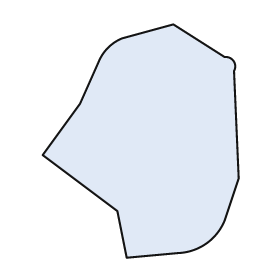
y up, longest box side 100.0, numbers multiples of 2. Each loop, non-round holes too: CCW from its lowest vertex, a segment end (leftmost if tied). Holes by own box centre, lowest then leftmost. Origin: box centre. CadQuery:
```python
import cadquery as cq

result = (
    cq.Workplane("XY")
    .moveTo(-6.0, -50.0)
    .lineTo(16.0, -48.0)
    .threePointArc((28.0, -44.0), (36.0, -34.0))
    .lineTo(42.0, -16.0)
    .lineTo(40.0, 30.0)
    .threePointArc((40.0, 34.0), (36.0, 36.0))
    .lineTo(14.0, 50.0)
    .lineTo(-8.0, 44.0)
    .threePointArc((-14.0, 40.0), (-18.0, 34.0))
    .lineTo(-26.0, 16.0)
    .lineTo(-42.0, -6.0)
    .lineTo(-10.0, -30.0)
    .close()
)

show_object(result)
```